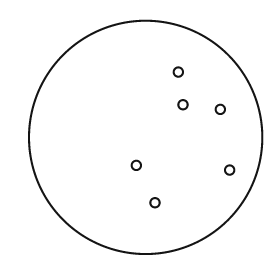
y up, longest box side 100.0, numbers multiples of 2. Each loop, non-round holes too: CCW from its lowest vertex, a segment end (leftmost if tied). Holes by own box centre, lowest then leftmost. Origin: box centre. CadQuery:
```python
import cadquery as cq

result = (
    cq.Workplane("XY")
    .moveTo(0.0, 0.0)
    .circle(50.0)
    .moveTo(4.0, -28.0)
    .circle(2.0)
    .moveTo(36.0, -14.0)
    .circle(2.0)
    .moveTo(-4.0, -12.0)
    .circle(2.0)
    .moveTo(32.0, 12.0)
    .circle(2.0)
    .moveTo(16.0, 14.0)
    .circle(2.0)
    .moveTo(14.0, 28.0)
    .circle(2.0)
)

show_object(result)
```